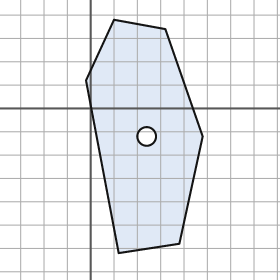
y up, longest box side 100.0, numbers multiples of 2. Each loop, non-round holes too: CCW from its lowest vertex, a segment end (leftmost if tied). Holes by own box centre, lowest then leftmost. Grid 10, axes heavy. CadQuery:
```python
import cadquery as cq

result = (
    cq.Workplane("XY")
    .moveTo(12.0, -62.0)
    .lineTo(38.0, -58.0)
    .lineTo(48.0, -12.0)
    .lineTo(32.0, 34.0)
    .lineTo(10.0, 38.0)
    .lineTo(-2.0, 12.0)
    .close()
    .moveTo(24.0, -12.0)
    .circle(4.0)
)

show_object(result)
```